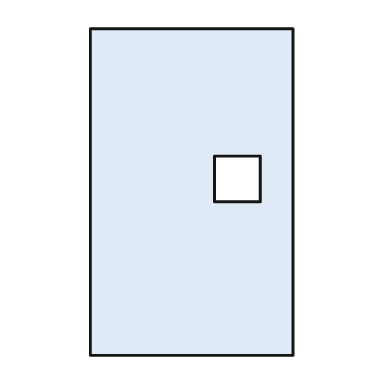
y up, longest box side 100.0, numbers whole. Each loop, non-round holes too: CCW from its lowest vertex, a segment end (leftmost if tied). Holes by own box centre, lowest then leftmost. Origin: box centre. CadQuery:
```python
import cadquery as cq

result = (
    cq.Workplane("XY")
    .moveTo(-31.0, -50.0)
    .lineTo(31.0, -50.0)
    .lineTo(31.0, 50.0)
    .lineTo(-31.0, 50.0)
    .close()
    .moveTo(7.0, -3.0)
    .lineTo(21.0, -3.0)
    .lineTo(21.0, 11.0)
    .lineTo(7.0, 11.0)
    .close()
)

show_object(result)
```